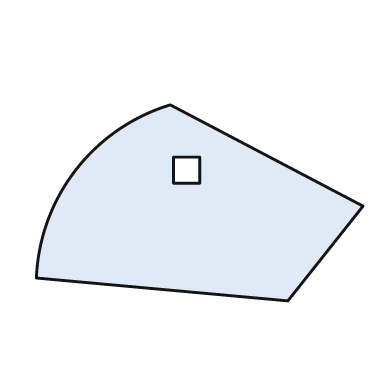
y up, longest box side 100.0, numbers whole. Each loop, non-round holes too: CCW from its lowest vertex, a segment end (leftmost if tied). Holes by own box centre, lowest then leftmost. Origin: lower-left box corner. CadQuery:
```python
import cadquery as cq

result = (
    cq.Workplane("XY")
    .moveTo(77.0, 0.0)
    .lineTo(100.0, 29.0)
    .lineTo(41.0, 60.0)
    .threePointArc((12.0, 40.0), (0.0, 7.0))
    .close()
    .moveTo(42.0, 36.0)
    .lineTo(50.0, 36.0)
    .lineTo(50.0, 44.0)
    .lineTo(42.0, 44.0)
    .close()
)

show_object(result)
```